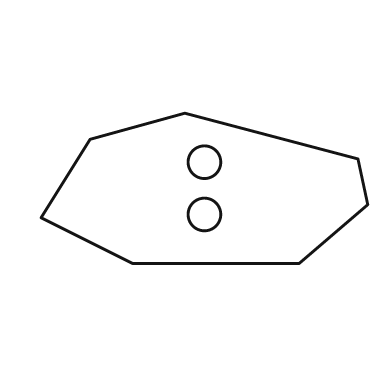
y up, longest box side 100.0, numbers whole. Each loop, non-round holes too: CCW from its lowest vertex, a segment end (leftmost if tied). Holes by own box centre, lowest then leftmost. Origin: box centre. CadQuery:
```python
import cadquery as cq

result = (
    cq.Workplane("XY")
    .moveTo(-22.0, -23.0)
    .lineTo(29.0, -23.0)
    .lineTo(50.0, -5.0)
    .lineTo(47.0, 9.0)
    .lineTo(-6.0, 23.0)
    .lineTo(-35.0, 15.0)
    .lineTo(-50.0, -9.0)
    .close()
    .moveTo(0.0, -8.0)
    .circle(5.0)
    .moveTo(0.0, 8.0)
    .circle(5.0)
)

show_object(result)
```